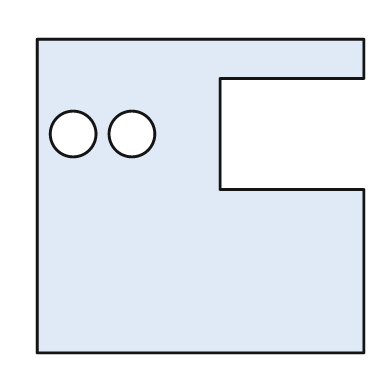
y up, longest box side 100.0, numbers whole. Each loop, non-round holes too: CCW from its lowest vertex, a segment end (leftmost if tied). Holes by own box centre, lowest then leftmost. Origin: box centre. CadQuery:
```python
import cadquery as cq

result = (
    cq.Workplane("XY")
    .moveTo(-50.0, -48.0)
    .lineTo(50.0, -48.0)
    .lineTo(50.0, 2.0)
    .lineTo(6.0, 2.0)
    .lineTo(6.0, 36.0)
    .lineTo(50.0, 36.0)
    .lineTo(50.0, 48.0)
    .lineTo(-50.0, 48.0)
    .close()
    .moveTo(-39.0, 19.0)
    .circle(7.0)
    .moveTo(-21.0, 19.0)
    .circle(7.0)
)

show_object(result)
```